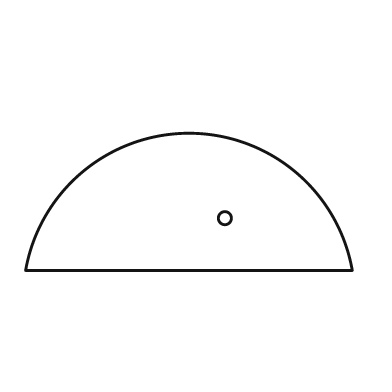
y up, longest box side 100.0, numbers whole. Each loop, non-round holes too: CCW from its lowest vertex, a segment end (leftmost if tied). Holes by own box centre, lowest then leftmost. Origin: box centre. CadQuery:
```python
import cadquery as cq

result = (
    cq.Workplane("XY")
    .moveTo(-50.0, -21.0)
    .lineTo(50.0, -21.0)
    .threePointArc((0.0, 21.0), (-50.0, -21.0))
    .close()
    .moveTo(11.0, -5.0)
    .circle(2.0)
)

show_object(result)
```